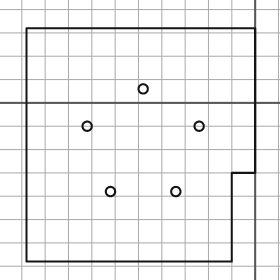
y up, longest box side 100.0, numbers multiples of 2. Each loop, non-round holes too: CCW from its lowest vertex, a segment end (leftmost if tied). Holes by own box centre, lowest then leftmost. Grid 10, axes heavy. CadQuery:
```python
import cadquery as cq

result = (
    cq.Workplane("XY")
    .moveTo(-98.0, -68.0)
    .lineTo(-10.0, -68.0)
    .lineTo(-10.0, -30.0)
    .lineTo(0.0, -30.0)
    .lineTo(0.0, 32.0)
    .lineTo(-98.0, 32.0)
    .close()
    .moveTo(-62.0, -38.0)
    .circle(2.0)
    .moveTo(-34.0, -38.0)
    .circle(2.0)
    .moveTo(-72.0, -10.0)
    .circle(2.0)
    .moveTo(-24.0, -10.0)
    .circle(2.0)
    .moveTo(-48.0, 6.0)
    .circle(2.0)
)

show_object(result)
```